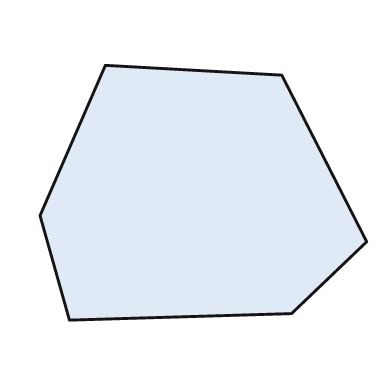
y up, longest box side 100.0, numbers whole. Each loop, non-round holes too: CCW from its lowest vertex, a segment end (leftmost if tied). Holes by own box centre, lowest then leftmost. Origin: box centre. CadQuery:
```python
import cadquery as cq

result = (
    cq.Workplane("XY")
    .moveTo(-41.0, -39.0)
    .lineTo(27.0, -37.0)
    .lineTo(50.0, -15.0)
    .lineTo(24.0, 36.0)
    .lineTo(-30.0, 39.0)
    .lineTo(-50.0, -7.0)
    .close()
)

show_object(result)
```